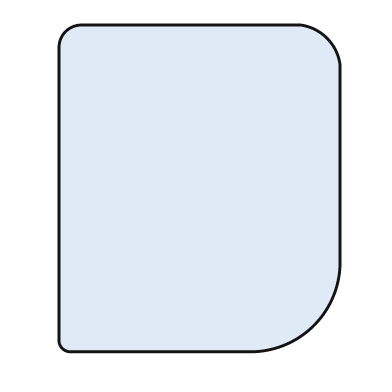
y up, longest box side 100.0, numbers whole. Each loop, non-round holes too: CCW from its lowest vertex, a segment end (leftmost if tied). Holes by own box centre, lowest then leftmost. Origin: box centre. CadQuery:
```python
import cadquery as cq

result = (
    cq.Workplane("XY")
    .moveTo(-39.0, -50.0)
    .lineTo(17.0, -50.0)
    .threePointArc((35.0, -42.0), (43.0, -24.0))
    .lineTo(43.0, 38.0)
    .threePointArc((39.0, 46.0), (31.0, 50.0))
    .lineTo(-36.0, 50.0)
    .threePointArc((-41.0, 48.0), (-43.0, 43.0))
    .lineTo(-43.0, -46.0)
    .threePointArc((-42.0, -49.0), (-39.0, -50.0))
    .close()
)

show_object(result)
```